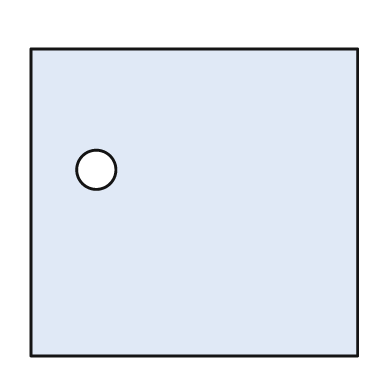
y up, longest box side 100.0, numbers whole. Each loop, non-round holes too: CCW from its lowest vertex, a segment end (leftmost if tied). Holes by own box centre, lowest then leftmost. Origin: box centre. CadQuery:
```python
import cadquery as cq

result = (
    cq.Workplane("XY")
    .moveTo(-50.0, -47.0)
    .lineTo(50.0, -47.0)
    .lineTo(50.0, 47.0)
    .lineTo(-50.0, 47.0)
    .close()
    .moveTo(-30.0, 10.0)
    .circle(6.0)
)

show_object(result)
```